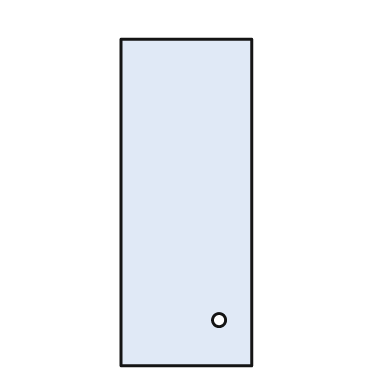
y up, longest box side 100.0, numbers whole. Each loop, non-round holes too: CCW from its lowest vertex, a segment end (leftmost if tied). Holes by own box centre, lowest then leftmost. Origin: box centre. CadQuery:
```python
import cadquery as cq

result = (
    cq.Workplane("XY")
    .moveTo(-20.0, -50.0)
    .lineTo(20.0, -50.0)
    .lineTo(20.0, 50.0)
    .lineTo(-20.0, 50.0)
    .close()
    .moveTo(10.0, -36.0)
    .circle(2.0)
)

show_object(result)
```